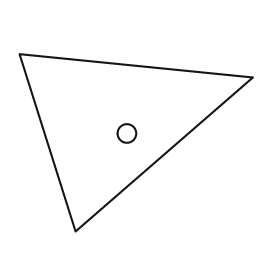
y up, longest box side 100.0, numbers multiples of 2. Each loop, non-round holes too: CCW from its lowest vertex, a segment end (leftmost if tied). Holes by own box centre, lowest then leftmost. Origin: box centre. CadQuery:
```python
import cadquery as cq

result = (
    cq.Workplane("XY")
    .moveTo(-26.0, -38.0)
    .lineTo(50.0, 28.0)
    .lineTo(-50.0, 38.0)
    .close()
    .moveTo(-4.0, 4.0)
    .circle(4.0)
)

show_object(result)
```